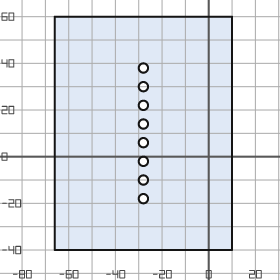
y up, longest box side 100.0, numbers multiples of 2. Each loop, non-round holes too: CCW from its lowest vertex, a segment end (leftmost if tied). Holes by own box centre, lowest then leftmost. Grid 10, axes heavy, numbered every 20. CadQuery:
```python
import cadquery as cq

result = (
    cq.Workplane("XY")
    .moveTo(-66.0, -40.0)
    .lineTo(10.0, -40.0)
    .lineTo(10.0, 60.0)
    .lineTo(-66.0, 60.0)
    .close()
    .moveTo(-28.0, -18.0)
    .circle(2.0)
    .moveTo(-28.0, -10.0)
    .circle(2.0)
    .moveTo(-28.0, -2.0)
    .circle(2.0)
    .moveTo(-28.0, 6.0)
    .circle(2.0)
    .moveTo(-28.0, 14.0)
    .circle(2.0)
    .moveTo(-28.0, 22.0)
    .circle(2.0)
    .moveTo(-28.0, 30.0)
    .circle(2.0)
    .moveTo(-28.0, 38.0)
    .circle(2.0)
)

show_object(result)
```